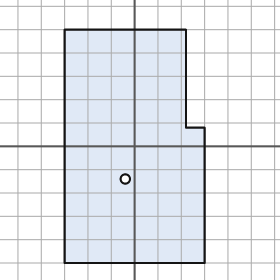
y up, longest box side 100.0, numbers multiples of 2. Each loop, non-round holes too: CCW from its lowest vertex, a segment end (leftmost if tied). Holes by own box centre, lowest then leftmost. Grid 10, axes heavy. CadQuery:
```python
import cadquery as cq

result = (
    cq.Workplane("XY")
    .moveTo(-30.0, -50.0)
    .lineTo(30.0, -50.0)
    .lineTo(30.0, 8.0)
    .lineTo(22.0, 8.0)
    .lineTo(22.0, 50.0)
    .lineTo(-30.0, 50.0)
    .close()
    .moveTo(-4.0, -14.0)
    .circle(2.0)
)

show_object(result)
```